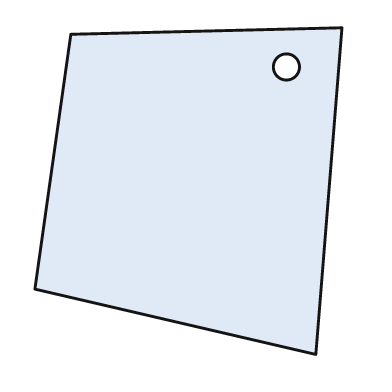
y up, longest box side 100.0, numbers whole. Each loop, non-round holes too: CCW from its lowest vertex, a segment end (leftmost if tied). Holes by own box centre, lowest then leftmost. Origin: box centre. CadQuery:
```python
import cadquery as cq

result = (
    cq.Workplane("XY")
    .moveTo(39.0, -50.0)
    .lineTo(47.0, 50.0)
    .lineTo(-36.0, 48.0)
    .lineTo(-47.0, -30.0)
    .close()
    .moveTo(30.0, 38.0)
    .circle(4.0)
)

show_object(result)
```